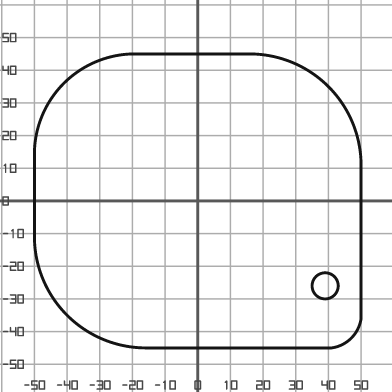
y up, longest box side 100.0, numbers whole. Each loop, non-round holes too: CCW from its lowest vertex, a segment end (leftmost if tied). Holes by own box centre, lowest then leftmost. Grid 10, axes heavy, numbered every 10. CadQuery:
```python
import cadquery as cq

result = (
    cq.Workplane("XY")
    .moveTo(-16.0, -45.0)
    .lineTo(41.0, -45.0)
    .threePointArc((47.0, -42.0), (50.0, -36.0))
    .lineTo(50.0, 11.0)
    .threePointArc((40.0, 35.0), (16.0, 45.0))
    .lineTo(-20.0, 45.0)
    .threePointArc((-41.0, 36.0), (-50.0, 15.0))
    .lineTo(-50.0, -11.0)
    .threePointArc((-40.0, -35.0), (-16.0, -45.0))
    .close()
    .moveTo(39.0, -26.0)
    .circle(4.0)
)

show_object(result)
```